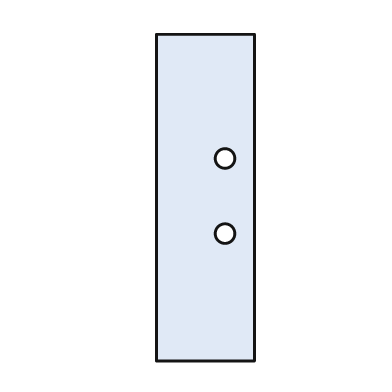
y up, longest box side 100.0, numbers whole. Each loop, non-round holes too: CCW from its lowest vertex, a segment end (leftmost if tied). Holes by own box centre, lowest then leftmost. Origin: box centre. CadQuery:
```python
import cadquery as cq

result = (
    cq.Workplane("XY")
    .moveTo(-15.0, -50.0)
    .lineTo(15.0, -50.0)
    .lineTo(15.0, 50.0)
    .lineTo(-15.0, 50.0)
    .close()
    .moveTo(6.0, -11.0)
    .circle(3.0)
    .moveTo(6.0, 12.0)
    .circle(3.0)
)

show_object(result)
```